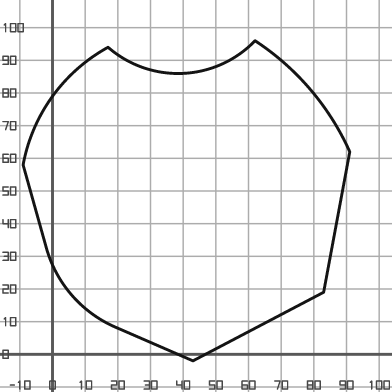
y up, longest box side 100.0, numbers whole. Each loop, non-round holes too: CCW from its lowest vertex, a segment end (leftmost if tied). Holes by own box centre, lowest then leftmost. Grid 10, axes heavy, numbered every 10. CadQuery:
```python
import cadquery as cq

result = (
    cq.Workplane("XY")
    .moveTo(43.0, -2.0)
    .lineTo(83.0, 19.0)
    .lineTo(91.0, 62.0)
    .threePointArc((79.0, 81.0), (62.0, 96.0))
    .threePointArc((40.0, 86.0), (17.0, 94.0))
    .threePointArc((0.0, 79.0), (-9.0, 58.0))
    .lineTo(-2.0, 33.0)
    .threePointArc((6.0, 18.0), (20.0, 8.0))
    .close()
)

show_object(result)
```